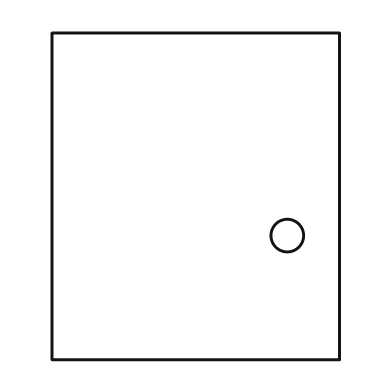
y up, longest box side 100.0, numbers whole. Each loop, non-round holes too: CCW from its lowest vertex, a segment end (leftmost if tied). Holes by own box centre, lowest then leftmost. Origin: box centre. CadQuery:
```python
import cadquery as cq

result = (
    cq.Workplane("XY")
    .moveTo(-44.0, -50.0)
    .lineTo(44.0, -50.0)
    .lineTo(44.0, 50.0)
    .lineTo(-44.0, 50.0)
    .close()
    .moveTo(28.0, -12.0)
    .circle(5.0)
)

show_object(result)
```